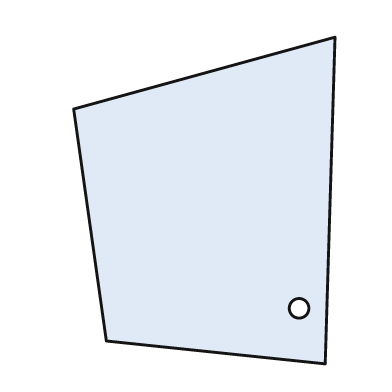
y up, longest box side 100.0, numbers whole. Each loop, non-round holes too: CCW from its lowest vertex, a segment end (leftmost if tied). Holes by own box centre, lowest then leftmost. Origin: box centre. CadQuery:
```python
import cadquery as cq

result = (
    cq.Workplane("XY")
    .moveTo(37.0, -50.0)
    .lineTo(40.0, 50.0)
    .lineTo(-40.0, 28.0)
    .lineTo(-30.0, -43.0)
    .close()
    .moveTo(29.0, -33.0)
    .circle(3.0)
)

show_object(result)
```